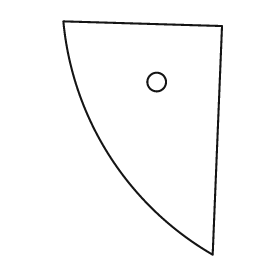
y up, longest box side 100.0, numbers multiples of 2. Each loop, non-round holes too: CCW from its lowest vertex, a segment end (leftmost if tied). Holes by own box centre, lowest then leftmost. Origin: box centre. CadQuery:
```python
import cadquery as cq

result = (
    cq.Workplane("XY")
    .moveTo(30.0, -50.0)
    .lineTo(34.0, 48.0)
    .lineTo(-34.0, 50.0)
    .threePointArc((-14.0, -8.0), (30.0, -50.0))
    .close()
    .moveTo(6.0, 24.0)
    .circle(4.0)
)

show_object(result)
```